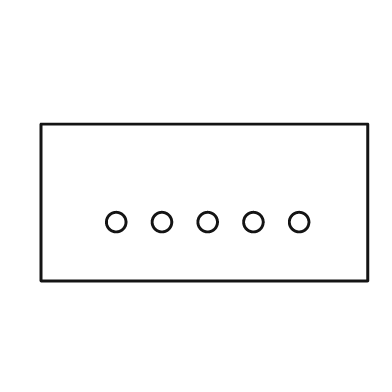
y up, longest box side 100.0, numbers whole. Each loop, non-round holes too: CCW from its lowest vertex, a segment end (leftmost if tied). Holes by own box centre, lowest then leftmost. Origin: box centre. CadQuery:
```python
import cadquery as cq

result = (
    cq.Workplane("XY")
    .moveTo(-50.0, -24.0)
    .lineTo(50.0, -24.0)
    .lineTo(50.0, 24.0)
    .lineTo(-50.0, 24.0)
    .close()
    .moveTo(-27.0, -6.0)
    .circle(3.0)
    .moveTo(-13.0, -6.0)
    .circle(3.0)
    .moveTo(1.0, -6.0)
    .circle(3.0)
    .moveTo(15.0, -6.0)
    .circle(3.0)
    .moveTo(29.0, -6.0)
    .circle(3.0)
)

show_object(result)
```